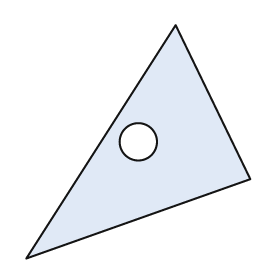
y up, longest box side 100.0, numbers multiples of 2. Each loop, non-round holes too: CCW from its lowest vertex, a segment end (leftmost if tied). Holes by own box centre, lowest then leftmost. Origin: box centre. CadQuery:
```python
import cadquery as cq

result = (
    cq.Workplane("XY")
    .moveTo(-48.0, -50.0)
    .lineTo(48.0, -16.0)
    .lineTo(16.0, 50.0)
    .close()
    .moveTo(0.0, 0.0)
    .circle(8.0)
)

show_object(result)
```